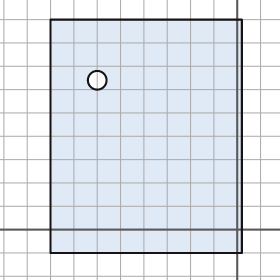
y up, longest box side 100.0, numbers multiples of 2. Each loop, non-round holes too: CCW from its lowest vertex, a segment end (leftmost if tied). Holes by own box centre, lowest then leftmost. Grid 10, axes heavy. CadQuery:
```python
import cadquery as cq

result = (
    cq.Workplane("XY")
    .moveTo(-80.0, -10.0)
    .lineTo(2.0, -10.0)
    .lineTo(2.0, 90.0)
    .lineTo(-80.0, 90.0)
    .close()
    .moveTo(-60.0, 64.0)
    .circle(4.0)
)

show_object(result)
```